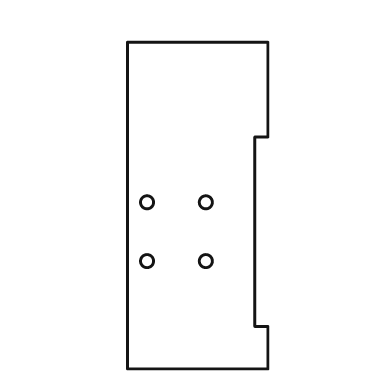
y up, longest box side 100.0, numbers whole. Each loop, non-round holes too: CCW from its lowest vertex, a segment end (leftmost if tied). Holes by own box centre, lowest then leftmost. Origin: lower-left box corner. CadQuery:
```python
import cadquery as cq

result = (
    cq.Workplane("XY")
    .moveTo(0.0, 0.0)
    .lineTo(43.0, 0.0)
    .lineTo(43.0, 13.0)
    .lineTo(39.0, 13.0)
    .lineTo(39.0, 71.0)
    .lineTo(43.0, 71.0)
    .lineTo(43.0, 100.0)
    .lineTo(0.0, 100.0)
    .close()
    .moveTo(6.0, 33.0)
    .circle(2.0)
    .moveTo(24.0, 33.0)
    .circle(2.0)
    .moveTo(6.0, 51.0)
    .circle(2.0)
    .moveTo(24.0, 51.0)
    .circle(2.0)
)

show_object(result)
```